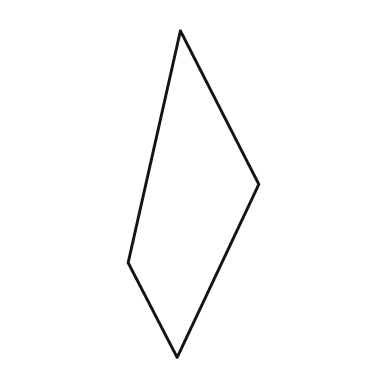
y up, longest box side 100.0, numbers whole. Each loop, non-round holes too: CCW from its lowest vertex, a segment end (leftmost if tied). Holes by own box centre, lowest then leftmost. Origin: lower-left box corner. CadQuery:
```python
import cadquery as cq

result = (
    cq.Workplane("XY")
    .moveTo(15.0, 0.0)
    .lineTo(40.0, 53.0)
    .lineTo(16.0, 100.0)
    .lineTo(0.0, 29.0)
    .close()
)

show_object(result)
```